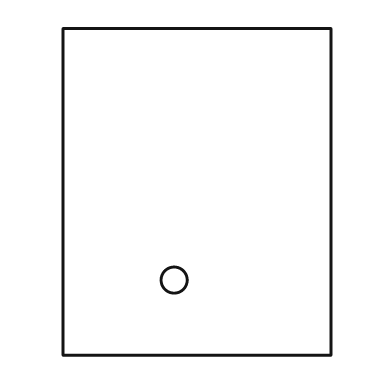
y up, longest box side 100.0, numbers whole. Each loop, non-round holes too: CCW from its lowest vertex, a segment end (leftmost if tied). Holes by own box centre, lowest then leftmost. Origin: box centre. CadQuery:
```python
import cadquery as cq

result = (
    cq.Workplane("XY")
    .moveTo(-41.0, -50.0)
    .lineTo(41.0, -50.0)
    .lineTo(41.0, 50.0)
    .lineTo(-41.0, 50.0)
    .close()
    .moveTo(-7.0, -27.0)
    .circle(4.0)
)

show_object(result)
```